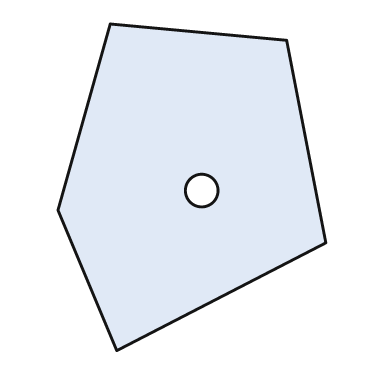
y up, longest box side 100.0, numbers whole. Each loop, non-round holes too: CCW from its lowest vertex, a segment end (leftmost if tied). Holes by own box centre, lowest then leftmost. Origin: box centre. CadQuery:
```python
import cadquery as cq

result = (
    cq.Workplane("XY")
    .moveTo(-23.0, -50.0)
    .lineTo(41.0, -17.0)
    .lineTo(29.0, 45.0)
    .lineTo(-25.0, 50.0)
    .lineTo(-41.0, -7.0)
    .close()
    .moveTo(3.0, -1.0)
    .circle(5.0)
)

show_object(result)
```